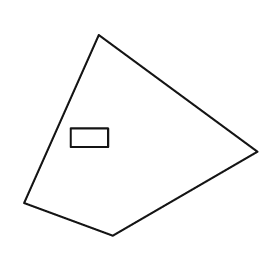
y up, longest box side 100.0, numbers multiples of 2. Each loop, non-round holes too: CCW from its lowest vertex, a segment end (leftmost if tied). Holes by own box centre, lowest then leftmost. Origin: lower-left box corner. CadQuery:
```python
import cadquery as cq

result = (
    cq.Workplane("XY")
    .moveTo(38.0, 0.0)
    .lineTo(100.0, 36.0)
    .lineTo(32.0, 86.0)
    .lineTo(0.0, 14.0)
    .close()
    .moveTo(20.0, 38.0)
    .lineTo(36.0, 38.0)
    .lineTo(36.0, 46.0)
    .lineTo(20.0, 46.0)
    .close()
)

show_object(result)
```